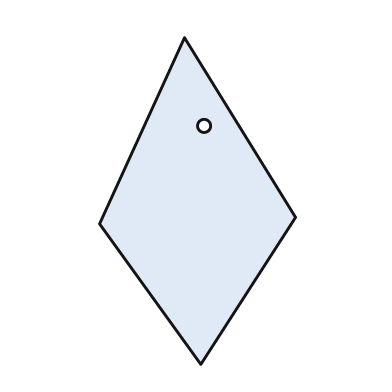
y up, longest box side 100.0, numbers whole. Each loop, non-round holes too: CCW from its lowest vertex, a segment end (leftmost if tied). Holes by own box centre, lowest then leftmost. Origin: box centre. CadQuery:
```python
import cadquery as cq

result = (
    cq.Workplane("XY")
    .moveTo(1.0, -50.0)
    .lineTo(30.0, -5.0)
    .lineTo(-4.0, 50.0)
    .lineTo(-30.0, -7.0)
    .close()
    .moveTo(2.0, 23.0)
    .circle(2.0)
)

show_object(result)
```